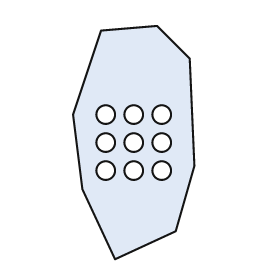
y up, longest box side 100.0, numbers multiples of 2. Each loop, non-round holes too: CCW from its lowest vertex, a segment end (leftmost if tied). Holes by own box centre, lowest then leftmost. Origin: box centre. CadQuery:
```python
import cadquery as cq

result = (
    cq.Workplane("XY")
    .moveTo(-8.0, -50.0)
    .lineTo(18.0, -38.0)
    .lineTo(26.0, -10.0)
    .lineTo(24.0, 36.0)
    .lineTo(10.0, 50.0)
    .lineTo(-14.0, 48.0)
    .lineTo(-26.0, 12.0)
    .lineTo(-22.0, -20.0)
    .close()
    .moveTo(-12.0, -12.0)
    .circle(4.0)
    .moveTo(0.0, -12.0)
    .circle(4.0)
    .moveTo(12.0, -12.0)
    .circle(4.0)
    .moveTo(-12.0, 0.0)
    .circle(4.0)
    .moveTo(0.0, 0.0)
    .circle(4.0)
    .moveTo(12.0, 0.0)
    .circle(4.0)
    .moveTo(-12.0, 12.0)
    .circle(4.0)
    .moveTo(0.0, 12.0)
    .circle(4.0)
    .moveTo(12.0, 12.0)
    .circle(4.0)
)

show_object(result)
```